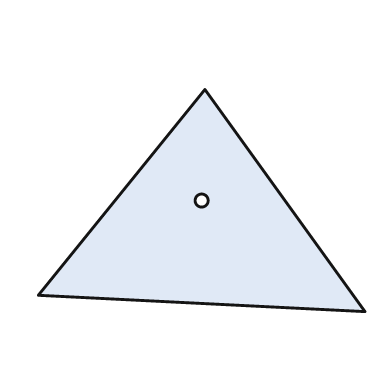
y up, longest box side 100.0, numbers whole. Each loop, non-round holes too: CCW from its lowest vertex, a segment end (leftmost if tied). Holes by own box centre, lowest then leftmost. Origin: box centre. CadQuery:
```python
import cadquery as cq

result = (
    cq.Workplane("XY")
    .moveTo(50.0, -34.0)
    .lineTo(1.0, 34.0)
    .lineTo(-50.0, -29.0)
    .close()
    .moveTo(0.0, 0.0)
    .circle(2.0)
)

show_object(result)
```